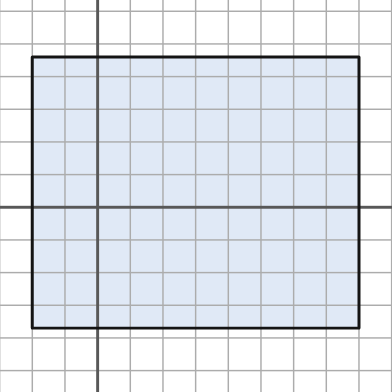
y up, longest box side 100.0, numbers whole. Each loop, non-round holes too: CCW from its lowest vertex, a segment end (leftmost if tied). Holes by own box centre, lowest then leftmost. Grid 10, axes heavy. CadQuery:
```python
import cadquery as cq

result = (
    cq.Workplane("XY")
    .moveTo(-20.0, -37.0)
    .lineTo(80.0, -37.0)
    .lineTo(80.0, 46.0)
    .lineTo(-20.0, 46.0)
    .close()
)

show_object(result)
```